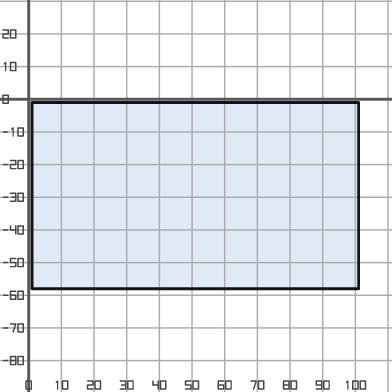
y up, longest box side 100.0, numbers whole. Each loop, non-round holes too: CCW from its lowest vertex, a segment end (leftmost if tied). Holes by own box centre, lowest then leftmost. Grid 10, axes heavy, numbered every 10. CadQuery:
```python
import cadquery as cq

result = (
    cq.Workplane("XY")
    .moveTo(1.0, -58.0)
    .lineTo(101.0, -58.0)
    .lineTo(101.0, -1.0)
    .lineTo(1.0, -1.0)
    .close()
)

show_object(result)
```